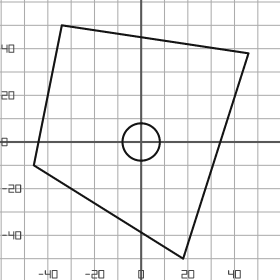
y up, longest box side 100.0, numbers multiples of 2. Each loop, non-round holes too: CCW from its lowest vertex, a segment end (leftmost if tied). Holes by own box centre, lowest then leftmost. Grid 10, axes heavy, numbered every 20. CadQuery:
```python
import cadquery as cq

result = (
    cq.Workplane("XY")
    .moveTo(18.0, -50.0)
    .lineTo(46.0, 38.0)
    .lineTo(-34.0, 50.0)
    .lineTo(-46.0, -10.0)
    .close()
    .moveTo(0.0, 0.0)
    .circle(8.0)
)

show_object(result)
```